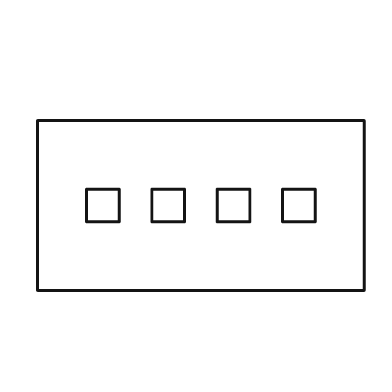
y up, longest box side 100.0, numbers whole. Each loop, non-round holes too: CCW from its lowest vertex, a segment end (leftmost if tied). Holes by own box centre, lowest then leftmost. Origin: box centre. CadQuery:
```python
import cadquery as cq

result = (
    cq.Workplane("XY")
    .moveTo(-50.0, -26.0)
    .lineTo(50.0, -26.0)
    .lineTo(50.0, 26.0)
    .lineTo(-50.0, 26.0)
    .close()
    .moveTo(-35.0, -5.0)
    .lineTo(-25.0, -5.0)
    .lineTo(-25.0, 5.0)
    .lineTo(-35.0, 5.0)
    .close()
    .moveTo(-15.0, -5.0)
    .lineTo(-5.0, -5.0)
    .lineTo(-5.0, 5.0)
    .lineTo(-15.0, 5.0)
    .close()
    .moveTo(5.0, -5.0)
    .lineTo(15.0, -5.0)
    .lineTo(15.0, 5.0)
    .lineTo(5.0, 5.0)
    .close()
    .moveTo(25.0, -5.0)
    .lineTo(35.0, -5.0)
    .lineTo(35.0, 5.0)
    .lineTo(25.0, 5.0)
    .close()
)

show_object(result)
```